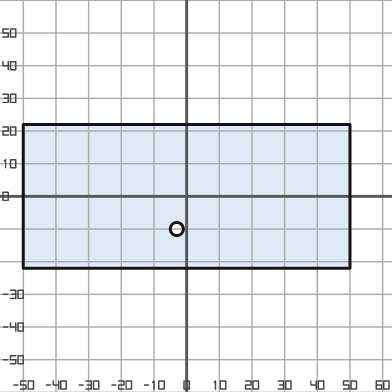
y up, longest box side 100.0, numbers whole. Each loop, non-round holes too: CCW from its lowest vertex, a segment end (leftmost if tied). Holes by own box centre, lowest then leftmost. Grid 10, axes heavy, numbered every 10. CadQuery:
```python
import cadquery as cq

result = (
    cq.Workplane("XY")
    .moveTo(-50.0, -22.0)
    .lineTo(50.0, -22.0)
    .lineTo(50.0, 22.0)
    .lineTo(-50.0, 22.0)
    .close()
    .moveTo(-3.0, -10.0)
    .circle(2.0)
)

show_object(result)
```